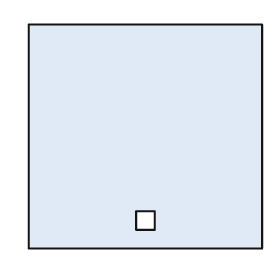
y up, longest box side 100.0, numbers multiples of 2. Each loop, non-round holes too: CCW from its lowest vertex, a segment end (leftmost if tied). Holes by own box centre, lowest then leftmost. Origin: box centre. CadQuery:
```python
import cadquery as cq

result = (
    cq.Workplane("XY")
    .moveTo(-50.0, -48.0)
    .lineTo(50.0, -48.0)
    .lineTo(50.0, 48.0)
    .lineTo(-50.0, 48.0)
    .close()
    .moveTo(-4.0, -40.0)
    .lineTo(4.0, -40.0)
    .lineTo(4.0, -32.0)
    .lineTo(-4.0, -32.0)
    .close()
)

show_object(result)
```